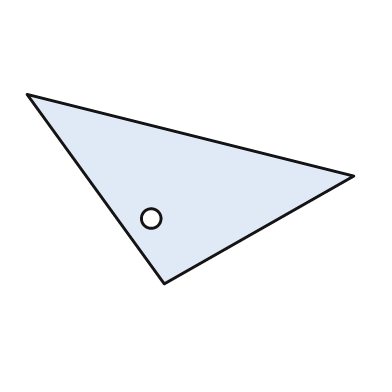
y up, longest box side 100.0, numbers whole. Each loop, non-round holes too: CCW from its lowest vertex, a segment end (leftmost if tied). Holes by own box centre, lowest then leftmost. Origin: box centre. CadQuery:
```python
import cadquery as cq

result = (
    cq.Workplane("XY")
    .moveTo(-8.0, -29.0)
    .lineTo(50.0, 4.0)
    .lineTo(-50.0, 29.0)
    .close()
    .moveTo(-12.0, -9.0)
    .circle(3.0)
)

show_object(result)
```